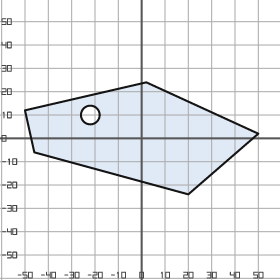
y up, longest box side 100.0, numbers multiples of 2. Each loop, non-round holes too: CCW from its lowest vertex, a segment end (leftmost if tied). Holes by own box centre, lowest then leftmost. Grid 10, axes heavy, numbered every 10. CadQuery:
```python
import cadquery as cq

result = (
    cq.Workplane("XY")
    .moveTo(20.0, -24.0)
    .lineTo(50.0, 2.0)
    .lineTo(2.0, 24.0)
    .lineTo(-50.0, 12.0)
    .lineTo(-46.0, -6.0)
    .close()
    .moveTo(-22.0, 10.0)
    .circle(4.0)
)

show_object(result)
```